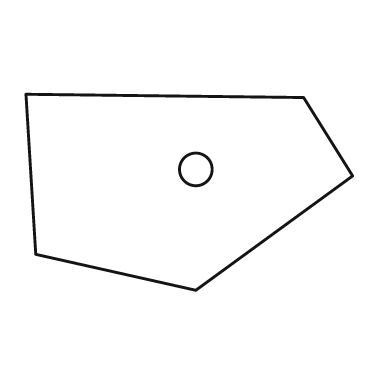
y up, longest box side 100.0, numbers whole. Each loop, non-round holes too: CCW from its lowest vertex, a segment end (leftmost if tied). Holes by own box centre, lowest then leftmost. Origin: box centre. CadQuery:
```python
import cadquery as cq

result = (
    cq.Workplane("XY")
    .moveTo(2.0, -30.0)
    .lineTo(50.0, 5.0)
    .lineTo(35.0, 29.0)
    .lineTo(-50.0, 30.0)
    .lineTo(-47.0, -19.0)
    .close()
    .moveTo(2.0, 7.0)
    .circle(5.0)
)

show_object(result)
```